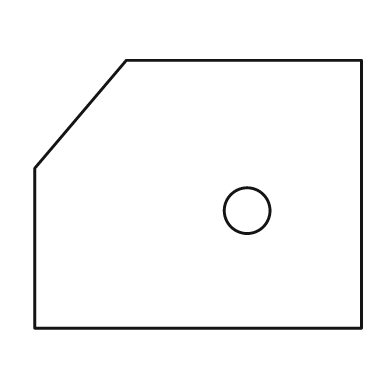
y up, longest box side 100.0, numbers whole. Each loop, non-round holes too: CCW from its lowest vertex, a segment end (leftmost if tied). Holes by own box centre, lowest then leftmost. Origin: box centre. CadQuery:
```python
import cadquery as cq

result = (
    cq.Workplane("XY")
    .moveTo(-50.0, -41.0)
    .lineTo(50.0, -41.0)
    .lineTo(50.0, 41.0)
    .lineTo(-22.0, 41.0)
    .lineTo(-50.0, 8.0)
    .close()
    .moveTo(15.0, -5.0)
    .circle(7.0)
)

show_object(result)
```